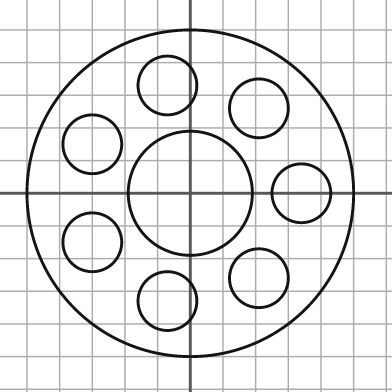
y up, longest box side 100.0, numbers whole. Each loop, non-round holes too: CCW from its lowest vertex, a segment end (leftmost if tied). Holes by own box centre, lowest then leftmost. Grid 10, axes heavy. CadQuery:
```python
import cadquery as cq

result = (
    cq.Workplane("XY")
    .moveTo(0.0, 0.0)
    .circle(50.0)
    .moveTo(-7.0, -33.0)
    .circle(9.0)
    .moveTo(21.0, -26.0)
    .circle(9.0)
    .moveTo(-30.0, -15.0)
    .circle(9.0)
    .moveTo(0.0, 0.0)
    .circle(19.0)
    .moveTo(34.0, 0.0)
    .circle(9.0)
    .moveTo(-30.0, 15.0)
    .circle(9.0)
    .moveTo(21.0, 26.0)
    .circle(9.0)
    .moveTo(-7.0, 33.0)
    .circle(9.0)
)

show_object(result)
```